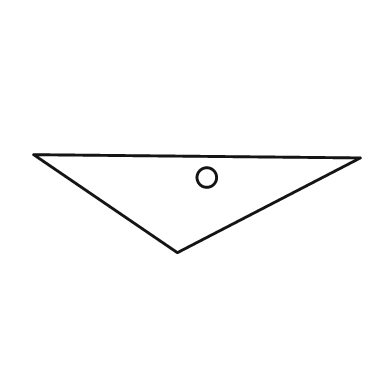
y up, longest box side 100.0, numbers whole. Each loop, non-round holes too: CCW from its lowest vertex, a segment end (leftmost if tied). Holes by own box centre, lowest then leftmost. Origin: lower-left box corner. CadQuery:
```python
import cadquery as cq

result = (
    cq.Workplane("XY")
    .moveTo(44.0, 0.0)
    .lineTo(100.0, 29.0)
    .lineTo(0.0, 30.0)
    .close()
    .moveTo(53.0, 23.0)
    .circle(3.0)
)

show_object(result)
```